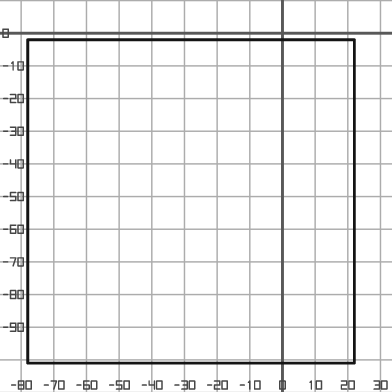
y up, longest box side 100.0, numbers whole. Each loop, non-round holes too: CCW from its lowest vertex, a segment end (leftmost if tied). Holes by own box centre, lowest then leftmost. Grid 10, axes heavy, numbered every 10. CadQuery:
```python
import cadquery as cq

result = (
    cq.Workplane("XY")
    .moveTo(-78.0, -101.0)
    .lineTo(22.0, -101.0)
    .lineTo(22.0, -2.0)
    .lineTo(-78.0, -2.0)
    .close()
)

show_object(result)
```